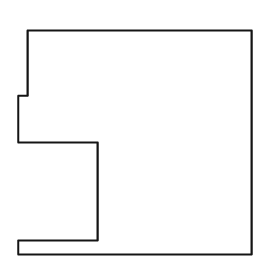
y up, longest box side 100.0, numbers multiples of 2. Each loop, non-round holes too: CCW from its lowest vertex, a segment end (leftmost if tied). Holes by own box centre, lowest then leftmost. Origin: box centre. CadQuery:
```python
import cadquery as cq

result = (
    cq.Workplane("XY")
    .moveTo(-50.0, -48.0)
    .lineTo(50.0, -48.0)
    .lineTo(50.0, 48.0)
    .lineTo(-46.0, 48.0)
    .lineTo(-46.0, 20.0)
    .lineTo(-50.0, 20.0)
    .lineTo(-50.0, 0.0)
    .lineTo(-16.0, 0.0)
    .lineTo(-16.0, -42.0)
    .lineTo(-50.0, -42.0)
    .close()
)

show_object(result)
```